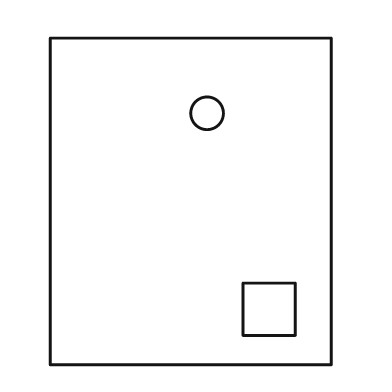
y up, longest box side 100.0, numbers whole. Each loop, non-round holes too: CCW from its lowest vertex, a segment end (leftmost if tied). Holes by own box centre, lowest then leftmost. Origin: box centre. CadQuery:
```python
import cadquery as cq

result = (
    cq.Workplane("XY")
    .moveTo(-43.0, -50.0)
    .lineTo(43.0, -50.0)
    .lineTo(43.0, 50.0)
    .lineTo(-43.0, 50.0)
    .close()
    .moveTo(16.0, -41.0)
    .lineTo(32.0, -41.0)
    .lineTo(32.0, -25.0)
    .lineTo(16.0, -25.0)
    .close()
    .moveTo(5.0, 27.0)
    .circle(5.0)
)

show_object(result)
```